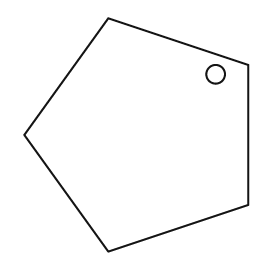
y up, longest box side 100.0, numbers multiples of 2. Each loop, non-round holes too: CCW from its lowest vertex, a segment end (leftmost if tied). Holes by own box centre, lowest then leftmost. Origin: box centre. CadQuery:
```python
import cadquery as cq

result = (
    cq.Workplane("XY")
    .moveTo(-12.0, -50.0)
    .lineTo(48.0, -30.0)
    .lineTo(48.0, 30.0)
    .lineTo(-12.0, 50.0)
    .lineTo(-48.0, 0.0)
    .close()
    .moveTo(34.0, 26.0)
    .circle(4.0)
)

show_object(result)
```